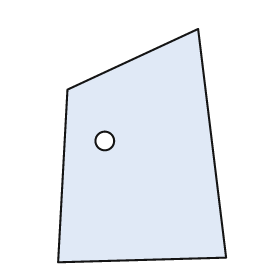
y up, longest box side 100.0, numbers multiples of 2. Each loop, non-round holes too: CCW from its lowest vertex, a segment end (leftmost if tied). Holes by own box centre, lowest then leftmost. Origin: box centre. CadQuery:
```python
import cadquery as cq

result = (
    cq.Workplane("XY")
    .moveTo(-36.0, -50.0)
    .lineTo(36.0, -48.0)
    .lineTo(24.0, 50.0)
    .lineTo(-32.0, 24.0)
    .close()
    .moveTo(-16.0, 2.0)
    .circle(4.0)
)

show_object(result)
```